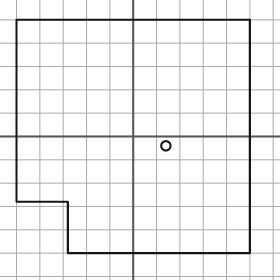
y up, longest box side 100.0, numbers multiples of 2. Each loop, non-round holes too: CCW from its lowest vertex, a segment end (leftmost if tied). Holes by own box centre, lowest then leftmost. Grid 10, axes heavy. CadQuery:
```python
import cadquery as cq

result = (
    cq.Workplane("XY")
    .moveTo(-28.0, -50.0)
    .lineTo(50.0, -50.0)
    .lineTo(50.0, 50.0)
    .lineTo(-50.0, 50.0)
    .lineTo(-50.0, -28.0)
    .lineTo(-28.0, -28.0)
    .close()
    .moveTo(14.0, -4.0)
    .circle(2.0)
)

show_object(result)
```